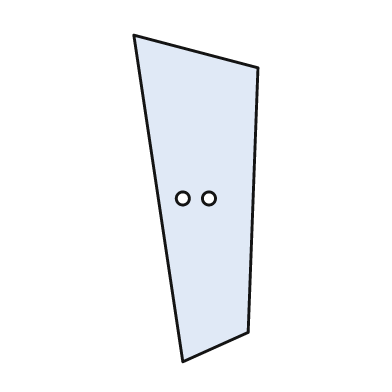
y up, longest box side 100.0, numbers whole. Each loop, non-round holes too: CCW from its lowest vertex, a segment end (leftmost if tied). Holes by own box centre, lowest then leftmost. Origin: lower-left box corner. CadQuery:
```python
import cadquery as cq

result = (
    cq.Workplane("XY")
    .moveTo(15.0, 0.0)
    .lineTo(35.0, 9.0)
    .lineTo(38.0, 90.0)
    .lineTo(0.0, 100.0)
    .close()
    .moveTo(15.0, 50.0)
    .circle(2.0)
    .moveTo(23.0, 50.0)
    .circle(2.0)
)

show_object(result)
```